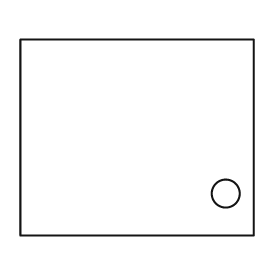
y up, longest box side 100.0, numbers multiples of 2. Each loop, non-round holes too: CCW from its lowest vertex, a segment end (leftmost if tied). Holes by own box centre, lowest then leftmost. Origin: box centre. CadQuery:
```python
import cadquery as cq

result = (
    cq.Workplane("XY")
    .moveTo(-50.0, -42.0)
    .lineTo(50.0, -42.0)
    .lineTo(50.0, 42.0)
    .lineTo(-50.0, 42.0)
    .close()
    .moveTo(38.0, -24.0)
    .circle(6.0)
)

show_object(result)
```